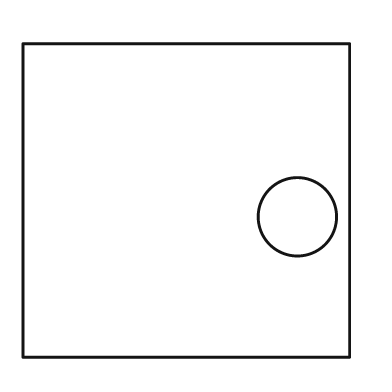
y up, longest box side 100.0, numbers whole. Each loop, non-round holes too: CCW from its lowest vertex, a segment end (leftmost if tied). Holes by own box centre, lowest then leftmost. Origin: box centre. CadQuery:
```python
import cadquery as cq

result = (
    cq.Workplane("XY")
    .moveTo(-50.0, -48.0)
    .lineTo(50.0, -48.0)
    .lineTo(50.0, 48.0)
    .lineTo(-50.0, 48.0)
    .close()
    .moveTo(34.0, -5.0)
    .circle(12.0)
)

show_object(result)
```